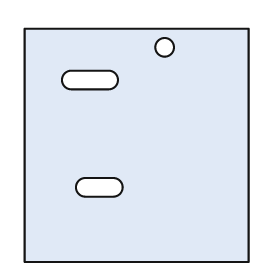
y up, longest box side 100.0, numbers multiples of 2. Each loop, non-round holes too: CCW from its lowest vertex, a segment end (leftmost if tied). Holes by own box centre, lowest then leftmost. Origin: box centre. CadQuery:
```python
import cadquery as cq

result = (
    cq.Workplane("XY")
    .moveTo(-48.0, -50.0)
    .lineTo(48.0, -50.0)
    .lineTo(48.0, 50.0)
    .lineTo(-48.0, 50.0)
    .close()
    .moveTo(-22.0, -22.0)
    .lineTo(-10.0, -22.0)
    .threePointArc((-6.0, -18.0), (-10.0, -14.0))
    .lineTo(-22.0, -14.0)
    .threePointArc((-26.0, -18.0), (-22.0, -22.0))
    .close()
    .moveTo(-28.0, 24.0)
    .lineTo(-12.0, 24.0)
    .threePointArc((-8.0, 28.0), (-12.0, 32.0))
    .lineTo(-28.0, 32.0)
    .threePointArc((-32.0, 28.0), (-28.0, 24.0))
    .close()
    .moveTo(12.0, 42.0)
    .circle(4.0)
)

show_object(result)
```